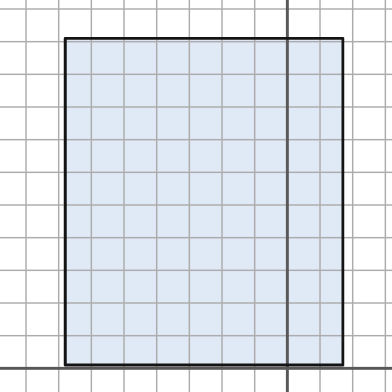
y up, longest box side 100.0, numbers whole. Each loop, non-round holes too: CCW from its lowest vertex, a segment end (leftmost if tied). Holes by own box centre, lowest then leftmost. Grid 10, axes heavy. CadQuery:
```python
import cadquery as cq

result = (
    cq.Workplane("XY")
    .moveTo(-68.0, 1.0)
    .lineTo(17.0, 1.0)
    .lineTo(17.0, 101.0)
    .lineTo(-68.0, 101.0)
    .close()
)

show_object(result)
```